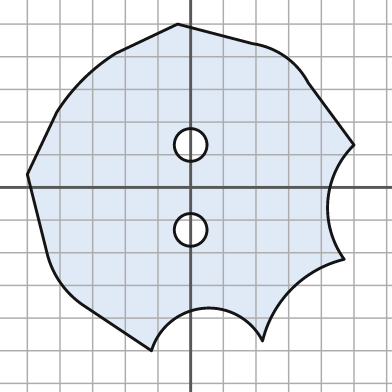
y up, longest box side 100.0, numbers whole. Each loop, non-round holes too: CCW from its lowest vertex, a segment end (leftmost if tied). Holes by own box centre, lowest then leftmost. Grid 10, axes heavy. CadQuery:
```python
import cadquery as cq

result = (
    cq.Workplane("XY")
    .moveTo(-12.0, -50.0)
    .threePointArc((4.0, -37.0), (22.0, -47.0))
    .threePointArc((31.0, -31.0), (47.0, -22.0))
    .threePointArc((42.0, -4.0), (50.0, 13.0))
    .lineTo(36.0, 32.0)
    .threePointArc((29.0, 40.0), (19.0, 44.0))
    .lineTo(-4.0, 50.0)
    .lineTo(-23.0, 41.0)
    .threePointArc((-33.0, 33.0), (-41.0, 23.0))
    .lineTo(-50.0, 4.0)
    .lineTo(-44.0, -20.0)
    .threePointArc((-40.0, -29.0), (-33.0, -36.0))
    .close()
    .moveTo(0.0, -13.0)
    .circle(5.0)
    .moveTo(0.0, 13.0)
    .circle(5.0)
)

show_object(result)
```